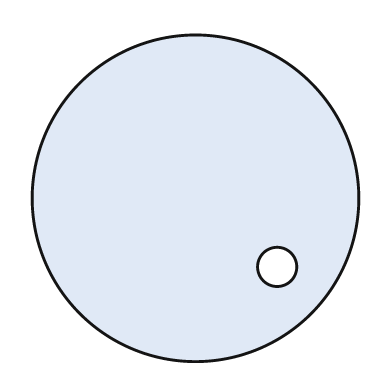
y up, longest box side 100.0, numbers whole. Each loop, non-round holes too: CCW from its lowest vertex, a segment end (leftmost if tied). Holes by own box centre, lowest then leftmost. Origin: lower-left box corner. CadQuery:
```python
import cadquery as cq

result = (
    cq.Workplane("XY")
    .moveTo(50.0, 50.0)
    .circle(50.0)
    .moveTo(75.0, 29.0)
    .circle(6.0)
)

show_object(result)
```